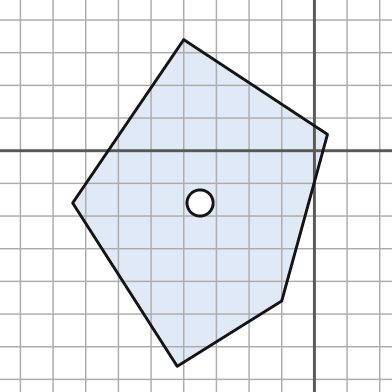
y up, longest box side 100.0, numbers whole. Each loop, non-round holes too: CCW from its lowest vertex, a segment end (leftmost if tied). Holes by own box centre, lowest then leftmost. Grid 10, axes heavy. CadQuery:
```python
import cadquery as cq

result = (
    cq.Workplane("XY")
    .moveTo(-42.0, -66.0)
    .lineTo(-10.0, -46.0)
    .lineTo(4.0, 5.0)
    .lineTo(-40.0, 34.0)
    .lineTo(-74.0, -16.0)
    .close()
    .moveTo(-35.0, -16.0)
    .circle(4.0)
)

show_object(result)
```